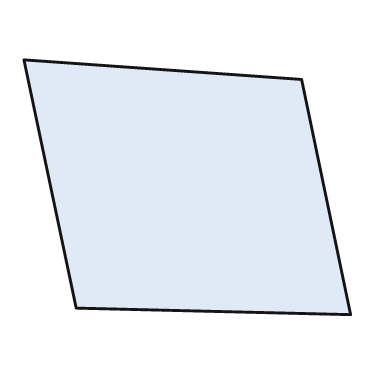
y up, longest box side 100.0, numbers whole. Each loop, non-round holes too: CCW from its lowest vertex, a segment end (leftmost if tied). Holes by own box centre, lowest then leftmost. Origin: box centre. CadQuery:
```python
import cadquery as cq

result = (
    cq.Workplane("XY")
    .moveTo(50.0, -39.0)
    .lineTo(35.0, 33.0)
    .lineTo(-50.0, 39.0)
    .lineTo(-34.0, -37.0)
    .close()
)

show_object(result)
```